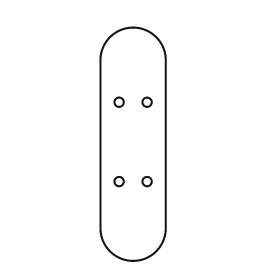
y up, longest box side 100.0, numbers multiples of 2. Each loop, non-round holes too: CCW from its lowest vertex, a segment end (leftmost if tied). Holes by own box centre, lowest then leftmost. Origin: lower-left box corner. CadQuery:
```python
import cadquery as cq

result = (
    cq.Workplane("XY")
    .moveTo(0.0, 14.0)
    .threePointArc((14.0, 0.0), (28.0, 14.0))
    .lineTo(28.0, 86.0)
    .threePointArc((14.0, 100.0), (0.0, 86.0))
    .close()
    .moveTo(8.0, 34.0)
    .circle(2.0)
    .moveTo(20.0, 34.0)
    .circle(2.0)
    .moveTo(8.0, 68.0)
    .circle(2.0)
    .moveTo(20.0, 68.0)
    .circle(2.0)
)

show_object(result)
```